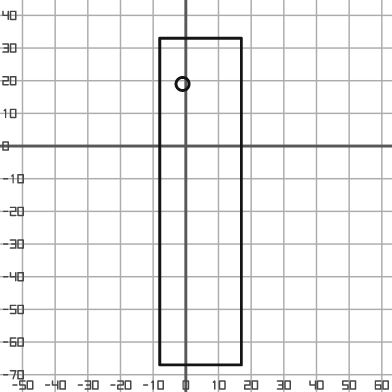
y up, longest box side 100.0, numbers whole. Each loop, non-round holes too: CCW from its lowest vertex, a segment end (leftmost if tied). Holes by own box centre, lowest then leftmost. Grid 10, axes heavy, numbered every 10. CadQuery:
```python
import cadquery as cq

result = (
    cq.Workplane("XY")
    .moveTo(-8.0, -67.0)
    .lineTo(17.0, -67.0)
    .lineTo(17.0, 33.0)
    .lineTo(-8.0, 33.0)
    .close()
    .moveTo(-1.0, 19.0)
    .circle(2.0)
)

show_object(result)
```